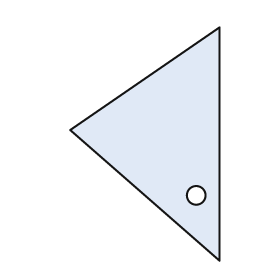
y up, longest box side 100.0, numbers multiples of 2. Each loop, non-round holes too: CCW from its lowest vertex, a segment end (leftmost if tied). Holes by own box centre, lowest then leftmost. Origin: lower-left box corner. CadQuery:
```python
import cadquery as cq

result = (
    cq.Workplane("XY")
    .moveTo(64.0, 0.0)
    .lineTo(64.0, 100.0)
    .lineTo(0.0, 56.0)
    .close()
    .moveTo(54.0, 28.0)
    .circle(4.0)
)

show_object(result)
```